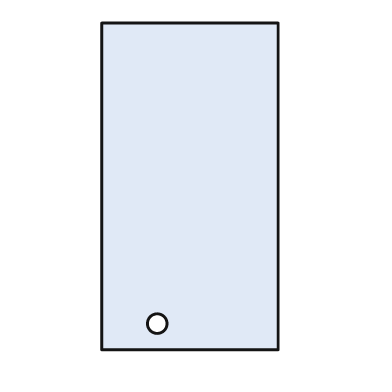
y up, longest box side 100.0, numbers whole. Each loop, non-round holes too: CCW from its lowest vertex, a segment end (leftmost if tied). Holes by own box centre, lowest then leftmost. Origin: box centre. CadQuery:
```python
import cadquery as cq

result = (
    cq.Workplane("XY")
    .moveTo(-27.0, -50.0)
    .lineTo(27.0, -50.0)
    .lineTo(27.0, 50.0)
    .lineTo(-27.0, 50.0)
    .close()
    .moveTo(-10.0, -42.0)
    .circle(3.0)
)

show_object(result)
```